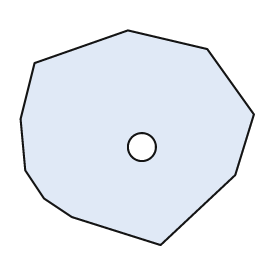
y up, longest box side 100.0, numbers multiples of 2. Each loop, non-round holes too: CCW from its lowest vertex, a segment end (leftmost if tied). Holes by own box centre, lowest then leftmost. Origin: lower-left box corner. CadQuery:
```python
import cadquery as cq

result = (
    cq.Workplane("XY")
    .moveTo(60.0, 0.0)
    .lineTo(92.0, 30.0)
    .lineTo(100.0, 56.0)
    .lineTo(80.0, 84.0)
    .lineTo(46.0, 92.0)
    .lineTo(6.0, 78.0)
    .lineTo(0.0, 54.0)
    .lineTo(2.0, 32.0)
    .lineTo(10.0, 20.0)
    .lineTo(22.0, 12.0)
    .close()
    .moveTo(52.0, 42.0)
    .circle(6.0)
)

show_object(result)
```